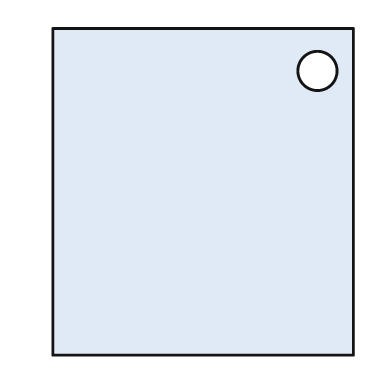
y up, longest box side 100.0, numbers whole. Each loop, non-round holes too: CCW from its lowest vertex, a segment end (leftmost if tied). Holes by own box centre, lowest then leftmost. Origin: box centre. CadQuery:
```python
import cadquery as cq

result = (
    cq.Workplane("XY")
    .moveTo(-46.0, -50.0)
    .lineTo(46.0, -50.0)
    .lineTo(46.0, 50.0)
    .lineTo(-46.0, 50.0)
    .close()
    .moveTo(35.0, 37.0)
    .circle(6.0)
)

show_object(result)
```